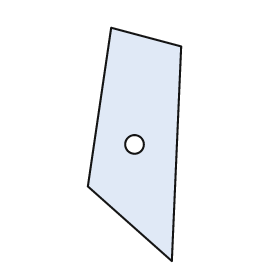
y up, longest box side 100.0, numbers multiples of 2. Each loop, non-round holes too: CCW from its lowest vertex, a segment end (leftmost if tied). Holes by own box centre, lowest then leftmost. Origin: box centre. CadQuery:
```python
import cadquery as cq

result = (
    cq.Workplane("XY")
    .moveTo(16.0, -50.0)
    .lineTo(20.0, 42.0)
    .lineTo(-10.0, 50.0)
    .lineTo(-20.0, -18.0)
    .close()
    .moveTo(0.0, 0.0)
    .circle(4.0)
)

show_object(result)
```